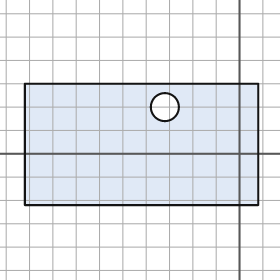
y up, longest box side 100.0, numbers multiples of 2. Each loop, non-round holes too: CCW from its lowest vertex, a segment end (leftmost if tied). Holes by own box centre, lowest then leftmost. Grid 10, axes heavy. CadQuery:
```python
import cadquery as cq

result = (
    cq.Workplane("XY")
    .moveTo(-92.0, -22.0)
    .lineTo(8.0, -22.0)
    .lineTo(8.0, 30.0)
    .lineTo(-92.0, 30.0)
    .close()
    .moveTo(-32.0, 20.0)
    .circle(6.0)
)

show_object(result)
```